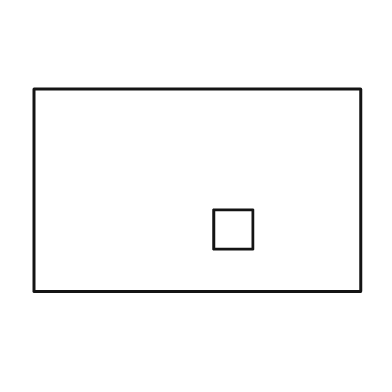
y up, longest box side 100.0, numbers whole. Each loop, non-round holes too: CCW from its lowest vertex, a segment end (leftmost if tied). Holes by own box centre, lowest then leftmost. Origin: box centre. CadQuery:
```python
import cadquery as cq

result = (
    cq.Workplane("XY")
    .moveTo(-50.0, -31.0)
    .lineTo(50.0, -31.0)
    .lineTo(50.0, 31.0)
    .lineTo(-50.0, 31.0)
    .close()
    .moveTo(5.0, -18.0)
    .lineTo(17.0, -18.0)
    .lineTo(17.0, -6.0)
    .lineTo(5.0, -6.0)
    .close()
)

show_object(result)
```